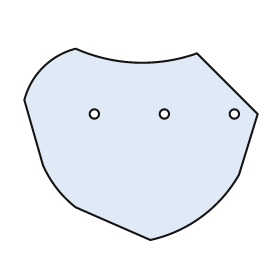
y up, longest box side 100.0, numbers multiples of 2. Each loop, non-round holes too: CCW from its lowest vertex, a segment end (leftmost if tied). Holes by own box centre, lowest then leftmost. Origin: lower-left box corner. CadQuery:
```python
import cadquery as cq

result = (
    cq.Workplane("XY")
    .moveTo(54.0, 0.0)
    .threePointArc((76.0, 10.0), (92.0, 28.0))
    .lineTo(100.0, 54.0)
    .lineTo(74.0, 80.0)
    .threePointArc((48.0, 76.0), (22.0, 82.0))
    .threePointArc((8.0, 74.0), (0.0, 60.0))
    .lineTo(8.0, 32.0)
    .threePointArc((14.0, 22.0), (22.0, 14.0))
    .close()
    .moveTo(30.0, 54.0)
    .circle(2.0)
    .moveTo(60.0, 54.0)
    .circle(2.0)
    .moveTo(90.0, 54.0)
    .circle(2.0)
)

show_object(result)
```